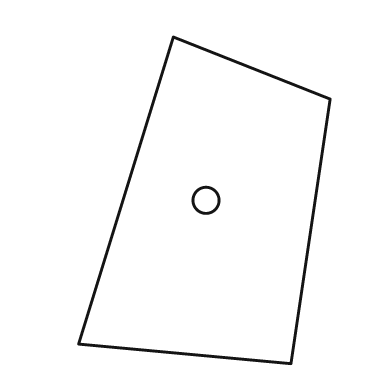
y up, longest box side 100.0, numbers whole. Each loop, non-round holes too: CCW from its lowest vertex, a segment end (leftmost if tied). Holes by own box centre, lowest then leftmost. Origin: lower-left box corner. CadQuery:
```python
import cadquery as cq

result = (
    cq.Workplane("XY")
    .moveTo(65.0, 0.0)
    .lineTo(77.0, 81.0)
    .lineTo(29.0, 100.0)
    .lineTo(0.0, 6.0)
    .close()
    .moveTo(39.0, 50.0)
    .circle(4.0)
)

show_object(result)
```